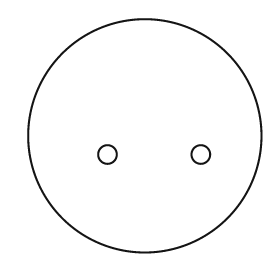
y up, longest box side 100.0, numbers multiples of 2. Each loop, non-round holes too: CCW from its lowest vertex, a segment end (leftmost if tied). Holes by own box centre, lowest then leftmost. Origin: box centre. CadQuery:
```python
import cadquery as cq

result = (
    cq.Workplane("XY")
    .moveTo(0.0, 0.0)
    .circle(50.0)
    .moveTo(-16.0, -8.0)
    .circle(4.0)
    .moveTo(24.0, -8.0)
    .circle(4.0)
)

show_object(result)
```